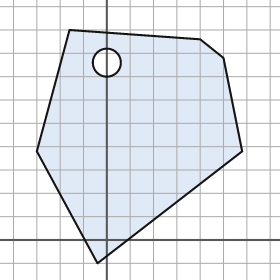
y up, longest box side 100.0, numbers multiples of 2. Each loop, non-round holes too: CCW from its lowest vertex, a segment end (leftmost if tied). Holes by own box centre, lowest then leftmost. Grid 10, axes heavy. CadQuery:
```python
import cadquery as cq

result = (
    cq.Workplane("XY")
    .moveTo(-4.0, -10.0)
    .lineTo(58.0, 38.0)
    .lineTo(50.0, 78.0)
    .lineTo(40.0, 86.0)
    .lineTo(-16.0, 90.0)
    .lineTo(-30.0, 38.0)
    .close()
    .moveTo(0.0, 76.0)
    .circle(6.0)
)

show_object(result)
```